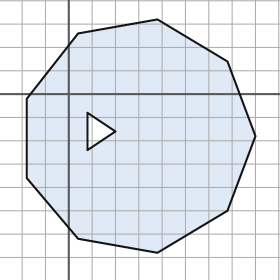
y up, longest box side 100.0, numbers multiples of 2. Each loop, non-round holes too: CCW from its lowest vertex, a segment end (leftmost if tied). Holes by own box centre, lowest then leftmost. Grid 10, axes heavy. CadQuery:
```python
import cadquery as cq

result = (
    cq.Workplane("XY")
    .moveTo(38.0, -68.0)
    .lineTo(68.0, -50.0)
    .lineTo(80.0, -18.0)
    .lineTo(68.0, 14.0)
    .lineTo(38.0, 32.0)
    .lineTo(4.0, 26.0)
    .lineTo(-18.0, -2.0)
    .lineTo(-18.0, -36.0)
    .lineTo(4.0, -62.0)
    .close()
    .moveTo(8.0, -24.0)
    .lineTo(20.0, -16.0)
    .lineTo(8.0, -8.0)
    .close()
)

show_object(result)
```